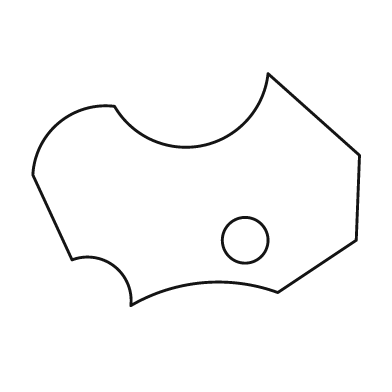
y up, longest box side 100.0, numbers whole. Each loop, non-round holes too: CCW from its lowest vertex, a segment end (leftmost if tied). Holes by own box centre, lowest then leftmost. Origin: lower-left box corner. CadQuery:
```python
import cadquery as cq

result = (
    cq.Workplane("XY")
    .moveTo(30.0, 0.0)
    .threePointArc((52.0, 7.0), (75.0, 4.0))
    .lineTo(99.0, 20.0)
    .lineTo(100.0, 46.0)
    .lineTo(72.0, 71.0)
    .threePointArc((52.0, 49.0), (25.0, 61.0))
    .threePointArc((8.0, 56.0), (0.0, 40.0))
    .lineTo(12.0, 14.0)
    .threePointArc((25.0, 12.0), (30.0, 0.0))
    .close()
    .moveTo(65.0, 20.0)
    .circle(7.0)
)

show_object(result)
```